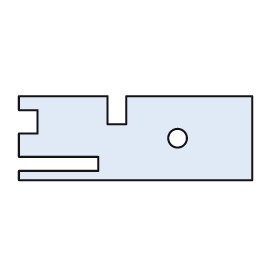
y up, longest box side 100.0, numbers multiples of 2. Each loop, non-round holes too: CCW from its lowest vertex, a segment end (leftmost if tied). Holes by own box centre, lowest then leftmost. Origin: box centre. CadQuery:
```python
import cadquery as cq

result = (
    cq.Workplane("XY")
    .moveTo(-50.0, -18.0)
    .lineTo(50.0, -18.0)
    .lineTo(50.0, 18.0)
    .lineTo(-4.0, 18.0)
    .lineTo(-4.0, 6.0)
    .lineTo(-12.0, 6.0)
    .lineTo(-12.0, 18.0)
    .lineTo(-50.0, 18.0)
    .lineTo(-50.0, 12.0)
    .lineTo(-42.0, 12.0)
    .lineTo(-42.0, 2.0)
    .lineTo(-50.0, 2.0)
    .lineTo(-50.0, -8.0)
    .lineTo(-16.0, -8.0)
    .lineTo(-16.0, -14.0)
    .lineTo(-50.0, -14.0)
    .close()
    .moveTo(18.0, 0.0)
    .circle(4.0)
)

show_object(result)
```